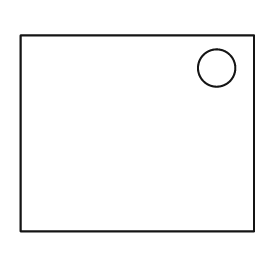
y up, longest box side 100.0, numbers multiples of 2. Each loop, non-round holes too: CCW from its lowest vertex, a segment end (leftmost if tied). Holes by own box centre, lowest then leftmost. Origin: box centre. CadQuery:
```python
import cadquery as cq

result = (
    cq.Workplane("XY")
    .moveTo(-50.0, -42.0)
    .lineTo(50.0, -42.0)
    .lineTo(50.0, 42.0)
    .lineTo(-50.0, 42.0)
    .close()
    .moveTo(34.0, 28.0)
    .circle(8.0)
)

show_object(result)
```